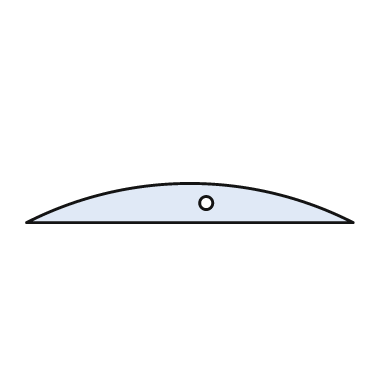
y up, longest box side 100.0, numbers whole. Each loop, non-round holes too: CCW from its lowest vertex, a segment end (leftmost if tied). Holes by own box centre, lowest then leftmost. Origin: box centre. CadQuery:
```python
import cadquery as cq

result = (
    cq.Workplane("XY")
    .moveTo(-50.0, -6.0)
    .lineTo(50.0, -6.0)
    .threePointArc((0.0, 6.0), (-50.0, -6.0))
    .close()
    .moveTo(5.0, 0.0)
    .circle(2.0)
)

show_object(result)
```